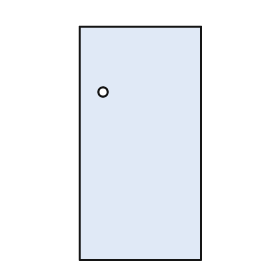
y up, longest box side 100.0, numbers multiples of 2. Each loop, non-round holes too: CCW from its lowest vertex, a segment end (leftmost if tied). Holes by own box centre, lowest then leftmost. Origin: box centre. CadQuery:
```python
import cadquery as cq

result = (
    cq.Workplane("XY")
    .moveTo(-26.0, -50.0)
    .lineTo(26.0, -50.0)
    .lineTo(26.0, 50.0)
    .lineTo(-26.0, 50.0)
    .close()
    .moveTo(-16.0, 22.0)
    .circle(2.0)
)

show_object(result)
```